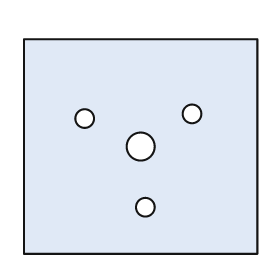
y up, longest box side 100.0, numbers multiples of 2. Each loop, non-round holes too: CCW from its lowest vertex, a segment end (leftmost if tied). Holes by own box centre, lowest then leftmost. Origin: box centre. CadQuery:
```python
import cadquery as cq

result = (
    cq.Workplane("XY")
    .moveTo(-50.0, -46.0)
    .lineTo(50.0, -46.0)
    .lineTo(50.0, 46.0)
    .lineTo(-50.0, 46.0)
    .close()
    .moveTo(2.0, -26.0)
    .circle(4.0)
    .moveTo(0.0, 0.0)
    .circle(6.0)
    .moveTo(-24.0, 12.0)
    .circle(4.0)
    .moveTo(22.0, 14.0)
    .circle(4.0)
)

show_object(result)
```